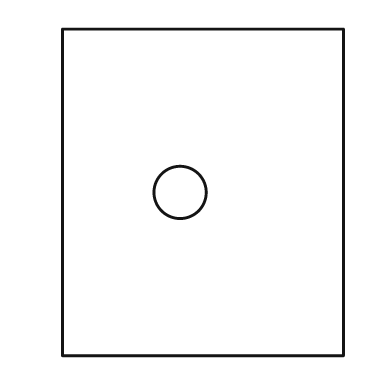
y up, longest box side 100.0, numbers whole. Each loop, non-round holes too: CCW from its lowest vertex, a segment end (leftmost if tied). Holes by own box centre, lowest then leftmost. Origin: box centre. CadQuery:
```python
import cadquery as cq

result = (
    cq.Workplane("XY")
    .moveTo(-43.0, -50.0)
    .lineTo(43.0, -50.0)
    .lineTo(43.0, 50.0)
    .lineTo(-43.0, 50.0)
    .close()
    .moveTo(-7.0, 0.0)
    .circle(8.0)
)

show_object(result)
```